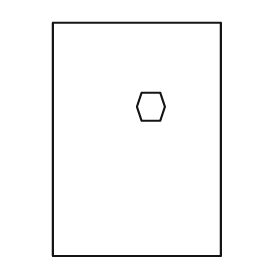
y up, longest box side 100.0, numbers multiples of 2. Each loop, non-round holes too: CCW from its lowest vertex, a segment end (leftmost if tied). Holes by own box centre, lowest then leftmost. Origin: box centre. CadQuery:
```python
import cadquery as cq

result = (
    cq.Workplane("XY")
    .moveTo(-36.0, -50.0)
    .lineTo(36.0, -50.0)
    .lineTo(36.0, 50.0)
    .lineTo(-36.0, 50.0)
    .close()
    .moveTo(2.0, 8.0)
    .lineTo(10.0, 8.0)
    .lineTo(12.0, 14.0)
    .lineTo(10.0, 20.0)
    .lineTo(2.0, 20.0)
    .lineTo(0.0, 14.0)
    .close()
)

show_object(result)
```